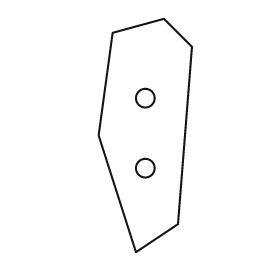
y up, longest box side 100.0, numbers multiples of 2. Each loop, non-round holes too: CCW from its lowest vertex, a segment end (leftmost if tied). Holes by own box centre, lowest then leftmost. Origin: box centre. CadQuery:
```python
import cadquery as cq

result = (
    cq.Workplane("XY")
    .moveTo(-4.0, -50.0)
    .lineTo(14.0, -38.0)
    .lineTo(20.0, 38.0)
    .lineTo(8.0, 50.0)
    .lineTo(-14.0, 44.0)
    .lineTo(-20.0, 0.0)
    .close()
    .moveTo(0.0, -14.0)
    .circle(4.0)
    .moveTo(0.0, 16.0)
    .circle(4.0)
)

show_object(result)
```